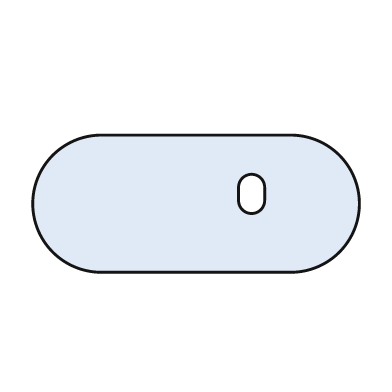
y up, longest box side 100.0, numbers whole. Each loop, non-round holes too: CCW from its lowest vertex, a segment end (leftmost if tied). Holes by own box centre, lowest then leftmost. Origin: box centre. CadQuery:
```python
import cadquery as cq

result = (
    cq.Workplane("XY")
    .moveTo(-29.0, -21.0)
    .lineTo(29.0, -21.0)
    .threePointArc((50.0, 0.0), (29.0, 21.0))
    .lineTo(-29.0, 21.0)
    .threePointArc((-50.0, 0.0), (-29.0, -21.0))
    .close()
    .moveTo(13.0, 1.0)
    .threePointArc((17.0, -3.0), (21.0, 1.0))
    .lineTo(21.0, 5.0)
    .threePointArc((17.0, 9.0), (13.0, 5.0))
    .close()
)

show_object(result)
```